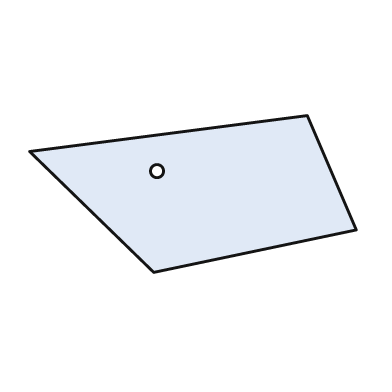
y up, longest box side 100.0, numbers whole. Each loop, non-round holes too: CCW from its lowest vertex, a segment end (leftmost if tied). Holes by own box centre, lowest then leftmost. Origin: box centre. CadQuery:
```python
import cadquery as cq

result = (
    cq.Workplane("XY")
    .moveTo(-12.0, -24.0)
    .lineTo(50.0, -11.0)
    .lineTo(35.0, 24.0)
    .lineTo(-50.0, 13.0)
    .close()
    .moveTo(-11.0, 7.0)
    .circle(2.0)
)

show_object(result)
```